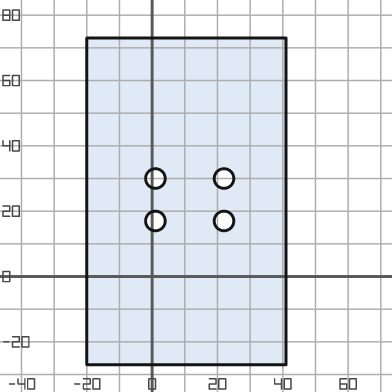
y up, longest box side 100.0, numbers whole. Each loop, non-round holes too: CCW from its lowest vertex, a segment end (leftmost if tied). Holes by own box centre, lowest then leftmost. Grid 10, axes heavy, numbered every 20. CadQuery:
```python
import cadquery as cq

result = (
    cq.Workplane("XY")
    .moveTo(-20.0, -27.0)
    .lineTo(41.0, -27.0)
    .lineTo(41.0, 73.0)
    .lineTo(-20.0, 73.0)
    .close()
    .moveTo(1.0, 17.0)
    .circle(3.0)
    .moveTo(22.0, 17.0)
    .circle(3.0)
    .moveTo(1.0, 30.0)
    .circle(3.0)
    .moveTo(22.0, 30.0)
    .circle(3.0)
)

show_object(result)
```